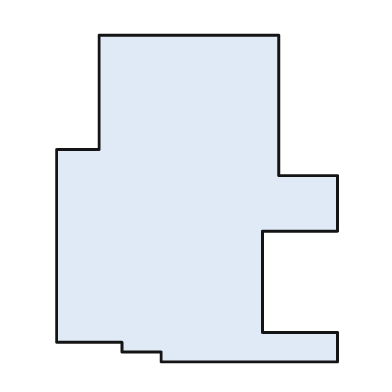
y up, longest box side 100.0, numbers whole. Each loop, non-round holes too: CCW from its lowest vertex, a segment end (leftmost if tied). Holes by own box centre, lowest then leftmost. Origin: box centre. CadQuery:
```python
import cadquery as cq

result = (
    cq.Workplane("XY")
    .moveTo(-11.0, -50.0)
    .lineTo(43.0, -50.0)
    .lineTo(43.0, -41.0)
    .lineTo(20.0, -41.0)
    .lineTo(20.0, -10.0)
    .lineTo(43.0, -10.0)
    .lineTo(43.0, 7.0)
    .lineTo(25.0, 7.0)
    .lineTo(25.0, 50.0)
    .lineTo(-30.0, 50.0)
    .lineTo(-30.0, 15.0)
    .lineTo(-43.0, 15.0)
    .lineTo(-43.0, -44.0)
    .lineTo(-23.0, -44.0)
    .lineTo(-23.0, -47.0)
    .lineTo(-11.0, -47.0)
    .close()
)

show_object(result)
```